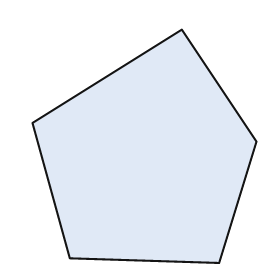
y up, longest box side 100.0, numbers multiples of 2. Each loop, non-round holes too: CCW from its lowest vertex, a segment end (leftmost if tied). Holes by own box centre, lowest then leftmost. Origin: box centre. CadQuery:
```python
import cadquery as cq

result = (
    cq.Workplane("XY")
    .moveTo(32.0, -50.0)
    .lineTo(48.0, 2.0)
    .lineTo(16.0, 50.0)
    .lineTo(-48.0, 10.0)
    .lineTo(-32.0, -48.0)
    .close()
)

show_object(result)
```